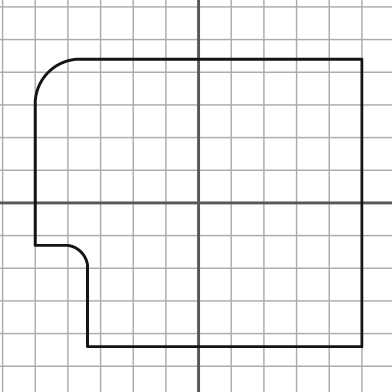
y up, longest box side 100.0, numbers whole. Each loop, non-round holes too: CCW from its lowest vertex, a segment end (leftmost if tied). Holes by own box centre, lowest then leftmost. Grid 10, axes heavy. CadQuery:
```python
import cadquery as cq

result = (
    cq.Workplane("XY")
    .moveTo(-34.0, -44.0)
    .lineTo(50.0, -44.0)
    .lineTo(50.0, 44.0)
    .lineTo(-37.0, 44.0)
    .threePointArc((-46.0, 40.0), (-50.0, 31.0))
    .lineTo(-50.0, -13.0)
    .lineTo(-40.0, -13.0)
    .threePointArc((-36.0, -15.0), (-34.0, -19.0))
    .close()
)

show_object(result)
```